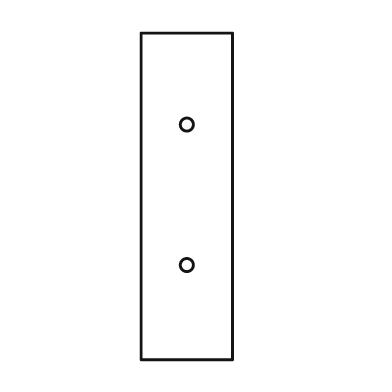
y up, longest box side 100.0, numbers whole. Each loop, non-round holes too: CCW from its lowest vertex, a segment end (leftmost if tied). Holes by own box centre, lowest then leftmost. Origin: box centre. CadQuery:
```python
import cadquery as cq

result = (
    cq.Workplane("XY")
    .moveTo(-14.0, -50.0)
    .lineTo(14.0, -50.0)
    .lineTo(14.0, 50.0)
    .lineTo(-14.0, 50.0)
    .close()
    .moveTo(0.0, -21.0)
    .circle(2.0)
    .moveTo(0.0, 22.0)
    .circle(2.0)
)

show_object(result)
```